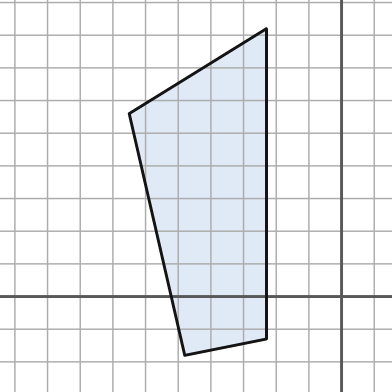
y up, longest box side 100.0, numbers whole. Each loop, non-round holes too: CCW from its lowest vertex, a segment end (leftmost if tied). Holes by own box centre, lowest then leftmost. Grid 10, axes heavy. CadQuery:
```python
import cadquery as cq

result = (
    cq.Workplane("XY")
    .moveTo(-48.0, -18.0)
    .lineTo(-23.0, -13.0)
    .lineTo(-23.0, 82.0)
    .lineTo(-65.0, 56.0)
    .close()
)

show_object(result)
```